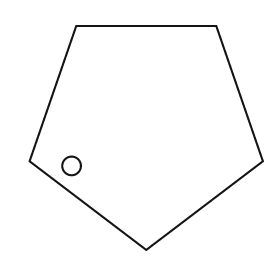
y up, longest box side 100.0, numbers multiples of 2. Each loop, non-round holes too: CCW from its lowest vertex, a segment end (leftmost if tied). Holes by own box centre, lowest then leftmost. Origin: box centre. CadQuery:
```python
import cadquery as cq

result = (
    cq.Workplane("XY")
    .moveTo(0.0, -48.0)
    .lineTo(50.0, -10.0)
    .lineTo(30.0, 48.0)
    .lineTo(-30.0, 48.0)
    .lineTo(-50.0, -10.0)
    .close()
    .moveTo(-32.0, -12.0)
    .circle(4.0)
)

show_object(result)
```